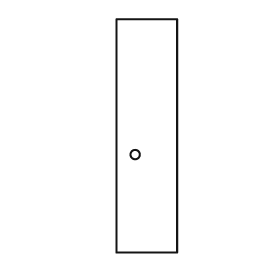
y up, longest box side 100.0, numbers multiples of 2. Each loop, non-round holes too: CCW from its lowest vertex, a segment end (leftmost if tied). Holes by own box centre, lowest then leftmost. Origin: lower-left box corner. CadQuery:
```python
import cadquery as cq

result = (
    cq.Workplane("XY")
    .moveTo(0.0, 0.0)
    .lineTo(26.0, 0.0)
    .lineTo(26.0, 100.0)
    .lineTo(0.0, 100.0)
    .close()
    .moveTo(8.0, 42.0)
    .circle(2.0)
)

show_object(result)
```